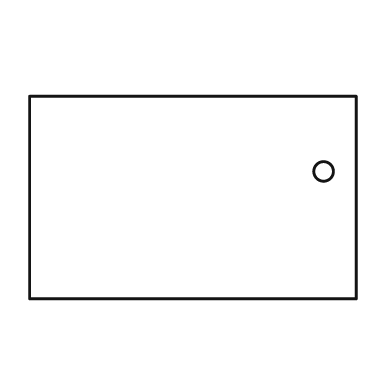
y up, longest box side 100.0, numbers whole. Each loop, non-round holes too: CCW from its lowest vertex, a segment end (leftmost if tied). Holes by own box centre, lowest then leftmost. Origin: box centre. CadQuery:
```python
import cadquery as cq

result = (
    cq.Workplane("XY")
    .moveTo(-50.0, -31.0)
    .lineTo(50.0, -31.0)
    .lineTo(50.0, 31.0)
    .lineTo(-50.0, 31.0)
    .close()
    .moveTo(40.0, 8.0)
    .circle(3.0)
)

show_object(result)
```